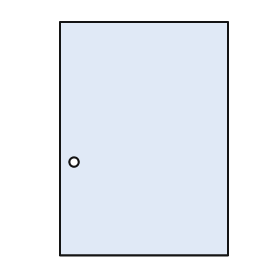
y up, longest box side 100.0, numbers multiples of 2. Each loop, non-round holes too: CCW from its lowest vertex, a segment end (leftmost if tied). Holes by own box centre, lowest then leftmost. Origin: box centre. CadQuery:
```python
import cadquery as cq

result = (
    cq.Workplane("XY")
    .moveTo(-36.0, -50.0)
    .lineTo(36.0, -50.0)
    .lineTo(36.0, 50.0)
    .lineTo(-36.0, 50.0)
    .close()
    .moveTo(-30.0, -10.0)
    .circle(2.0)
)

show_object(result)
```